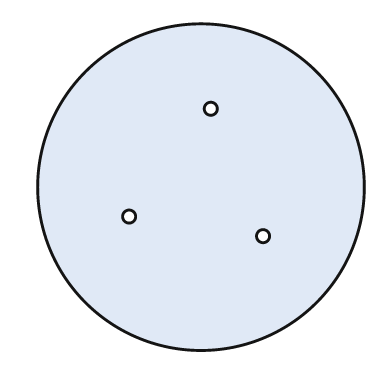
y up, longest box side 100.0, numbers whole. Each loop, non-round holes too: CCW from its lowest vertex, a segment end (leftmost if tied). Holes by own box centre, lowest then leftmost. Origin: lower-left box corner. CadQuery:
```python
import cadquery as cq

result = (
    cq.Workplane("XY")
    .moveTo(50.0, 50.0)
    .circle(50.0)
    .moveTo(69.0, 35.0)
    .circle(2.0)
    .moveTo(28.0, 41.0)
    .circle(2.0)
    .moveTo(53.0, 74.0)
    .circle(2.0)
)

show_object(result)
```